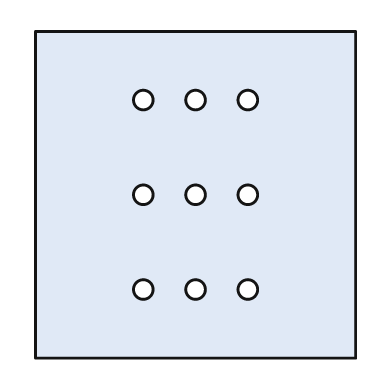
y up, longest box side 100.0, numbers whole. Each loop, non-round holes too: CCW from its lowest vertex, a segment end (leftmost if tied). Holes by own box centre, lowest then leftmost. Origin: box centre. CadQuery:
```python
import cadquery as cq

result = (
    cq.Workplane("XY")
    .moveTo(-49.0, -50.0)
    .lineTo(49.0, -50.0)
    .lineTo(49.0, 50.0)
    .lineTo(-49.0, 50.0)
    .close()
    .moveTo(-16.0, -29.0)
    .circle(3.0)
    .moveTo(0.0, -29.0)
    .circle(3.0)
    .moveTo(16.0, -29.0)
    .circle(3.0)
    .moveTo(-16.0, 0.0)
    .circle(3.0)
    .moveTo(0.0, 0.0)
    .circle(3.0)
    .moveTo(16.0, 0.0)
    .circle(3.0)
    .moveTo(-16.0, 29.0)
    .circle(3.0)
    .moveTo(0.0, 29.0)
    .circle(3.0)
    .moveTo(16.0, 29.0)
    .circle(3.0)
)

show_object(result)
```